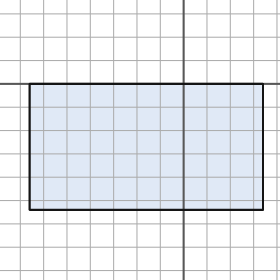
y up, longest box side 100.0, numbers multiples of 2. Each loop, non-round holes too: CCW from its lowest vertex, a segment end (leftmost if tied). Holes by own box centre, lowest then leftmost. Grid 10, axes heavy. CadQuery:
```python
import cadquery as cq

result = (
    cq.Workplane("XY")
    .moveTo(-66.0, -54.0)
    .lineTo(34.0, -54.0)
    .lineTo(34.0, 0.0)
    .lineTo(-66.0, 0.0)
    .close()
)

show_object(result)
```